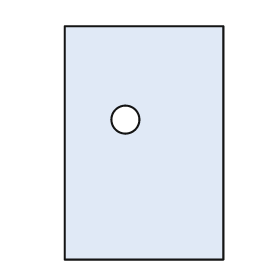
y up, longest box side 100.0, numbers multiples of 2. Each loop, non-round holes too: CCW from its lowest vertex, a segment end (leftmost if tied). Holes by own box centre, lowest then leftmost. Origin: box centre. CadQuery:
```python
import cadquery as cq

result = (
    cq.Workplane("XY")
    .moveTo(-34.0, -50.0)
    .lineTo(34.0, -50.0)
    .lineTo(34.0, 50.0)
    .lineTo(-34.0, 50.0)
    .close()
    .moveTo(-8.0, 10.0)
    .circle(6.0)
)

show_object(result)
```